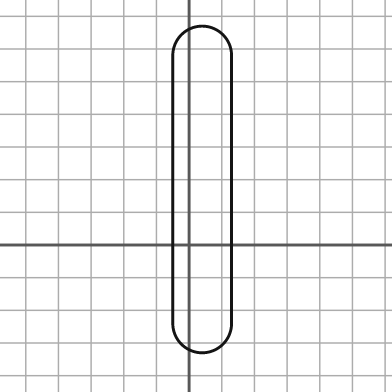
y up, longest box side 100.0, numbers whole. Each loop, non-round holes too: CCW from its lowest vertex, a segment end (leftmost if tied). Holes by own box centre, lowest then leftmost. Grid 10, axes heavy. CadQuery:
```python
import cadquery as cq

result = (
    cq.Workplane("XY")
    .moveTo(-5.0, -24.0)
    .threePointArc((4.0, -33.0), (13.0, -24.0))
    .lineTo(13.0, 58.0)
    .threePointArc((4.0, 67.0), (-5.0, 58.0))
    .close()
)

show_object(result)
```